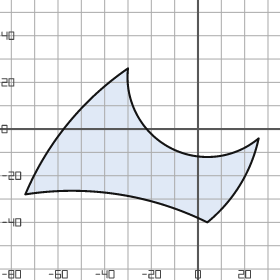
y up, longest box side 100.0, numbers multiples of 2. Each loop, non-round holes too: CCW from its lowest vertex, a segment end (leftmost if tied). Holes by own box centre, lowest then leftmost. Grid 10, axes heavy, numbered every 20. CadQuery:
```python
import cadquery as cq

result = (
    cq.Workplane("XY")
    .moveTo(4.0, -40.0)
    .threePointArc((18.0, -24.0), (26.0, -4.0))
    .threePointArc((-12.0, -8.0), (-30.0, 26.0))
    .threePointArc((-56.0, 2.0), (-74.0, -28.0))
    .threePointArc((-34.0, -28.0), (4.0, -40.0))
    .close()
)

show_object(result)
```